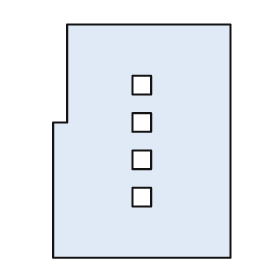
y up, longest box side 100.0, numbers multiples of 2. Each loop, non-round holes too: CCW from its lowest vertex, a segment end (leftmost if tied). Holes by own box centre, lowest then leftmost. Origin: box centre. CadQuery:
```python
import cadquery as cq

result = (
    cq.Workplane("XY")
    .moveTo(-38.0, -50.0)
    .lineTo(38.0, -50.0)
    .lineTo(38.0, 50.0)
    .lineTo(-32.0, 50.0)
    .lineTo(-32.0, 8.0)
    .lineTo(-38.0, 8.0)
    .close()
    .moveTo(-4.0, -28.0)
    .lineTo(4.0, -28.0)
    .lineTo(4.0, -20.0)
    .lineTo(-4.0, -20.0)
    .close()
    .moveTo(-4.0, -12.0)
    .lineTo(4.0, -12.0)
    .lineTo(4.0, -4.0)
    .lineTo(-4.0, -4.0)
    .close()
    .moveTo(-4.0, 4.0)
    .lineTo(4.0, 4.0)
    .lineTo(4.0, 12.0)
    .lineTo(-4.0, 12.0)
    .close()
    .moveTo(-4.0, 20.0)
    .lineTo(4.0, 20.0)
    .lineTo(4.0, 28.0)
    .lineTo(-4.0, 28.0)
    .close()
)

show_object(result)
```